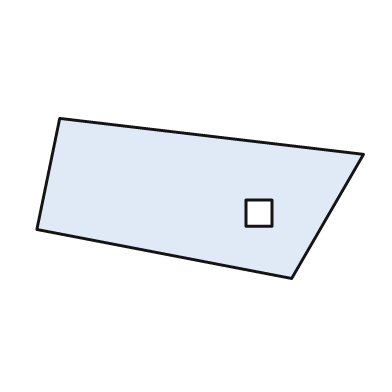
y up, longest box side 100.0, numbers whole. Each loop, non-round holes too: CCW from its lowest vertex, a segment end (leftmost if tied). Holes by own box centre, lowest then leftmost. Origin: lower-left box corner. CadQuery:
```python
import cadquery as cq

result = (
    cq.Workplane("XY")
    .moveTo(78.0, 0.0)
    .lineTo(100.0, 38.0)
    .lineTo(7.0, 49.0)
    .lineTo(0.0, 15.0)
    .close()
    .moveTo(64.0, 16.0)
    .lineTo(72.0, 16.0)
    .lineTo(72.0, 24.0)
    .lineTo(64.0, 24.0)
    .close()
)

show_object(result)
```